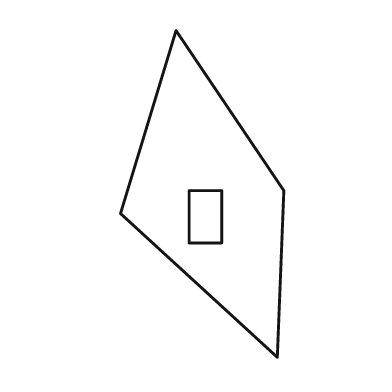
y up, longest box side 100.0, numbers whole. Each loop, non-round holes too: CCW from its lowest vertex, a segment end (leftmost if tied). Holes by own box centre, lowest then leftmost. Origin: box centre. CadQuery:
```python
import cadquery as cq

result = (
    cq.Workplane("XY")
    .moveTo(23.0, -50.0)
    .lineTo(25.0, 1.0)
    .lineTo(-8.0, 50.0)
    .lineTo(-25.0, -6.0)
    .close()
    .moveTo(-4.0, -15.0)
    .lineTo(6.0, -15.0)
    .lineTo(6.0, 1.0)
    .lineTo(-4.0, 1.0)
    .close()
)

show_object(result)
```